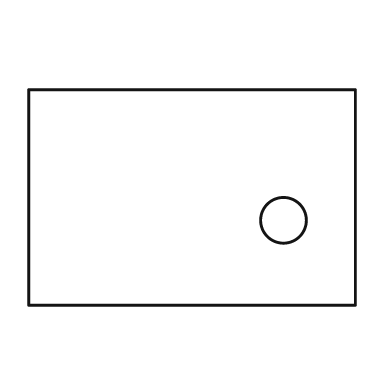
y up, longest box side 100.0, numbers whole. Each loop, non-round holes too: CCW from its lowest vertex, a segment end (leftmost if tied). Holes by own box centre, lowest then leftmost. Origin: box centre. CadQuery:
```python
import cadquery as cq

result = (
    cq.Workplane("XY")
    .moveTo(-50.0, -33.0)
    .lineTo(50.0, -33.0)
    .lineTo(50.0, 33.0)
    .lineTo(-50.0, 33.0)
    .close()
    .moveTo(28.0, -7.0)
    .circle(7.0)
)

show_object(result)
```